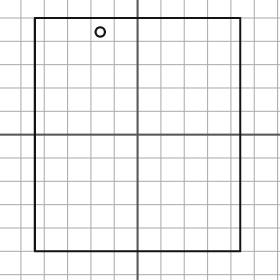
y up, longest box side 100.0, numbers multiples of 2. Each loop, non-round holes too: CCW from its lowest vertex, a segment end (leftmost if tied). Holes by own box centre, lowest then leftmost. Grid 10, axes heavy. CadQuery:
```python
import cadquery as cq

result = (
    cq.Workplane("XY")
    .moveTo(-44.0, -50.0)
    .lineTo(44.0, -50.0)
    .lineTo(44.0, 50.0)
    .lineTo(-44.0, 50.0)
    .close()
    .moveTo(-16.0, 44.0)
    .circle(2.0)
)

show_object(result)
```